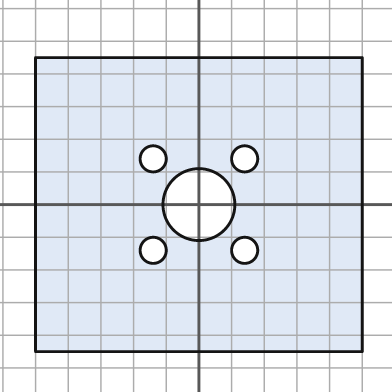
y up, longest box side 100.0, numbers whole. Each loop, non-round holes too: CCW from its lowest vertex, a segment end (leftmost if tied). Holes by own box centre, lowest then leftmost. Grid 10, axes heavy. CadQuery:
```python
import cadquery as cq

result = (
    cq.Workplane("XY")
    .moveTo(-50.0, -45.0)
    .lineTo(50.0, -45.0)
    .lineTo(50.0, 45.0)
    .lineTo(-50.0, 45.0)
    .close()
    .moveTo(-14.0, -14.0)
    .circle(4.0)
    .moveTo(14.0, -14.0)
    .circle(4.0)
    .moveTo(0.0, 0.0)
    .circle(11.0)
    .moveTo(-14.0, 14.0)
    .circle(4.0)
    .moveTo(14.0, 14.0)
    .circle(4.0)
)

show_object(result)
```